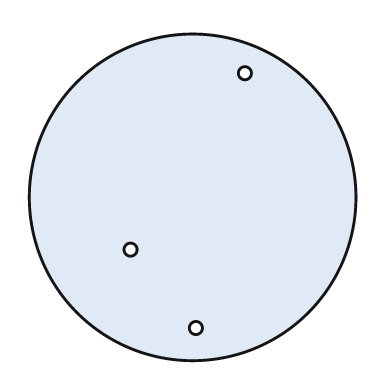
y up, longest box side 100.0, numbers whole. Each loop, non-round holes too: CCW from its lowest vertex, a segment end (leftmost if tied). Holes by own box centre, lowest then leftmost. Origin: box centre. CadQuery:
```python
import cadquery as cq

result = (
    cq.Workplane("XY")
    .moveTo(0.0, 0.0)
    .circle(50.0)
    .moveTo(1.0, -40.0)
    .circle(2.0)
    .moveTo(-19.0, -16.0)
    .circle(2.0)
    .moveTo(16.0, 38.0)
    .circle(2.0)
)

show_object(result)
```